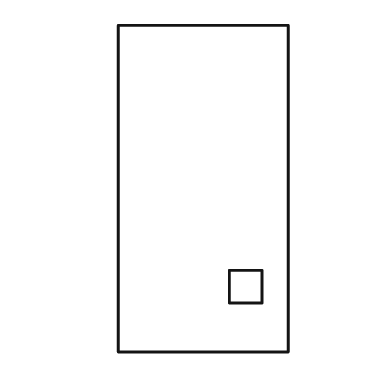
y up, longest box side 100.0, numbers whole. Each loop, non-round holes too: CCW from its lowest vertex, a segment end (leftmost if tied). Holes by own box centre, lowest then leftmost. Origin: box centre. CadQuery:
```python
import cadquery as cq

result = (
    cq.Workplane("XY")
    .moveTo(-26.0, -50.0)
    .lineTo(26.0, -50.0)
    .lineTo(26.0, 50.0)
    .lineTo(-26.0, 50.0)
    .close()
    .moveTo(8.0, -35.0)
    .lineTo(18.0, -35.0)
    .lineTo(18.0, -25.0)
    .lineTo(8.0, -25.0)
    .close()
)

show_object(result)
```